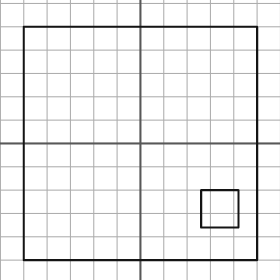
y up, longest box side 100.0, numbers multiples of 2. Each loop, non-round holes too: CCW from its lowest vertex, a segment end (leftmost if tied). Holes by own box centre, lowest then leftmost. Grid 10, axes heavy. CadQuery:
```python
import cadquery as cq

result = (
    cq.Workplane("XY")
    .moveTo(-50.0, -50.0)
    .lineTo(50.0, -50.0)
    .lineTo(50.0, 50.0)
    .lineTo(-50.0, 50.0)
    .close()
    .moveTo(26.0, -36.0)
    .lineTo(42.0, -36.0)
    .lineTo(42.0, -20.0)
    .lineTo(26.0, -20.0)
    .close()
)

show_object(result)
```